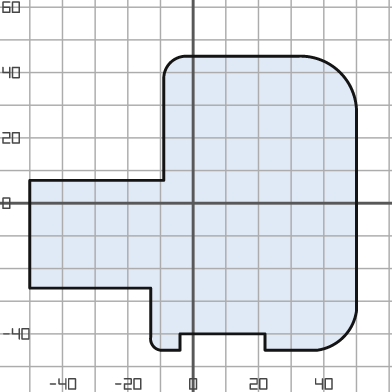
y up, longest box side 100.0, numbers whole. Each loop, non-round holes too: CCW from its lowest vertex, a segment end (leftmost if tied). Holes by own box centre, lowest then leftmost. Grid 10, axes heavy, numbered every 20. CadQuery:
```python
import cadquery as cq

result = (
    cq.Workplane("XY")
    .moveTo(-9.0, -45.0)
    .lineTo(-4.0, -45.0)
    .lineTo(-4.0, -40.0)
    .lineTo(22.0, -40.0)
    .lineTo(22.0, -45.0)
    .lineTo(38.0, -45.0)
    .threePointArc((46.0, -41.0), (50.0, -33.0))
    .lineTo(50.0, 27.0)
    .threePointArc((45.0, 40.0), (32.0, 45.0))
    .lineTo(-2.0, 45.0)
    .threePointArc((-7.0, 43.0), (-9.0, 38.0))
    .lineTo(-9.0, 7.0)
    .lineTo(-50.0, 7.0)
    .lineTo(-50.0, -26.0)
    .lineTo(-13.0, -26.0)
    .lineTo(-13.0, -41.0)
    .threePointArc((-12.0, -44.0), (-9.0, -45.0))
    .close()
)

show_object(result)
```